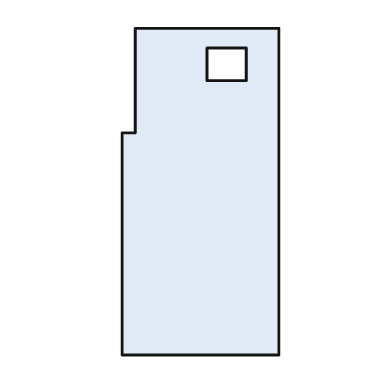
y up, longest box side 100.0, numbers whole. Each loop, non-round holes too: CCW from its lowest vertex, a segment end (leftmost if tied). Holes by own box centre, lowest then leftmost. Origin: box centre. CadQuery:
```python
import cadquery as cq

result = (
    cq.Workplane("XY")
    .moveTo(-24.0, -50.0)
    .lineTo(24.0, -50.0)
    .lineTo(24.0, 50.0)
    .lineTo(-20.0, 50.0)
    .lineTo(-20.0, 18.0)
    .lineTo(-24.0, 18.0)
    .close()
    .moveTo(2.0, 34.0)
    .lineTo(14.0, 34.0)
    .lineTo(14.0, 44.0)
    .lineTo(2.0, 44.0)
    .close()
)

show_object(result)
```